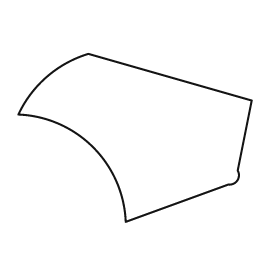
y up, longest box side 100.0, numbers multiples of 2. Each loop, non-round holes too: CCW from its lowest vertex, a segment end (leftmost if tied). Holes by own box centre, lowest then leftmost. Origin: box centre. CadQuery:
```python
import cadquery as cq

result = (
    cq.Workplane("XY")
    .moveTo(-4.0, -36.0)
    .lineTo(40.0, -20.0)
    .threePointArc((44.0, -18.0), (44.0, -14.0))
    .lineTo(50.0, 16.0)
    .lineTo(-20.0, 36.0)
    .threePointArc((-38.0, 26.0), (-50.0, 10.0))
    .threePointArc((-18.0, -4.0), (-4.0, -36.0))
    .close()
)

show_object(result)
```